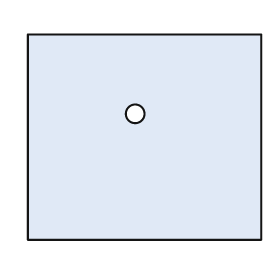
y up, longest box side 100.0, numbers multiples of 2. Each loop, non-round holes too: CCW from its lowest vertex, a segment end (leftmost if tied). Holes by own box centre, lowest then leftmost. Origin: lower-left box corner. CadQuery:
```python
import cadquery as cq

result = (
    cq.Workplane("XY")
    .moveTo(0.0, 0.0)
    .lineTo(100.0, 0.0)
    .lineTo(100.0, 88.0)
    .lineTo(0.0, 88.0)
    .close()
    .moveTo(46.0, 54.0)
    .circle(4.0)
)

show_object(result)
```